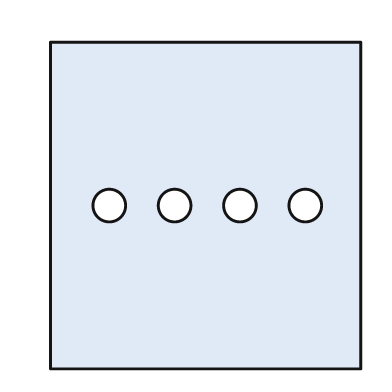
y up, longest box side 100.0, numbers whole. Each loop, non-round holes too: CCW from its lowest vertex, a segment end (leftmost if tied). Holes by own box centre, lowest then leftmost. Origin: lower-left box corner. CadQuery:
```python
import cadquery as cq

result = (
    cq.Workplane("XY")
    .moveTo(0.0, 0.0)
    .lineTo(95.0, 0.0)
    .lineTo(95.0, 100.0)
    .lineTo(0.0, 100.0)
    .close()
    .moveTo(18.0, 50.0)
    .circle(5.0)
    .moveTo(38.0, 50.0)
    .circle(5.0)
    .moveTo(58.0, 50.0)
    .circle(5.0)
    .moveTo(78.0, 50.0)
    .circle(5.0)
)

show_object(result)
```